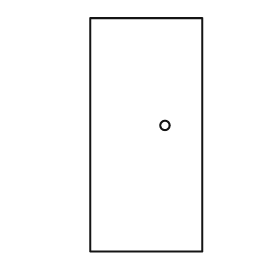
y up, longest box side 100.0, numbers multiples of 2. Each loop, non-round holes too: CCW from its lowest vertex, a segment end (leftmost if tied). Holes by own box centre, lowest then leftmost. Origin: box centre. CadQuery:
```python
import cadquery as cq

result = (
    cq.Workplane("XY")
    .moveTo(-24.0, -50.0)
    .lineTo(24.0, -50.0)
    .lineTo(24.0, 50.0)
    .lineTo(-24.0, 50.0)
    .close()
    .moveTo(8.0, 4.0)
    .circle(2.0)
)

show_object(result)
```